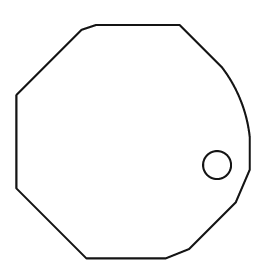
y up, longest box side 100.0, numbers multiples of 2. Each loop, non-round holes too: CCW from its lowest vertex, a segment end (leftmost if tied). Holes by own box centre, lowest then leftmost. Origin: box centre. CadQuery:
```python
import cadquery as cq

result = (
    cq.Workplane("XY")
    .moveTo(-20.0, -50.0)
    .lineTo(14.0, -50.0)
    .lineTo(24.0, -46.0)
    .lineTo(44.0, -26.0)
    .lineTo(50.0, -12.0)
    .lineTo(50.0, 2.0)
    .threePointArc((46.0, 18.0), (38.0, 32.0))
    .lineTo(20.0, 50.0)
    .lineTo(-16.0, 50.0)
    .lineTo(-22.0, 48.0)
    .lineTo(-50.0, 20.0)
    .lineTo(-50.0, -20.0)
    .close()
    .moveTo(36.0, -10.0)
    .circle(6.0)
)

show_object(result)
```